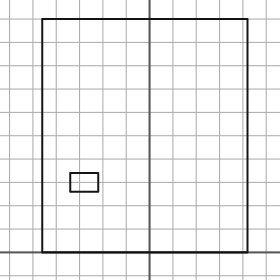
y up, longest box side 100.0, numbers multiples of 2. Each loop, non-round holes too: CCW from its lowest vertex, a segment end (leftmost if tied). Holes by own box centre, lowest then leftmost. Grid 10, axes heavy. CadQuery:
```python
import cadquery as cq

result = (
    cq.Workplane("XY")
    .moveTo(-46.0, 0.0)
    .lineTo(42.0, 0.0)
    .lineTo(42.0, 100.0)
    .lineTo(-46.0, 100.0)
    .close()
    .moveTo(-34.0, 26.0)
    .lineTo(-22.0, 26.0)
    .lineTo(-22.0, 34.0)
    .lineTo(-34.0, 34.0)
    .close()
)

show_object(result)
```